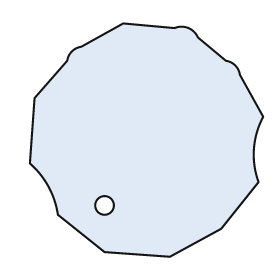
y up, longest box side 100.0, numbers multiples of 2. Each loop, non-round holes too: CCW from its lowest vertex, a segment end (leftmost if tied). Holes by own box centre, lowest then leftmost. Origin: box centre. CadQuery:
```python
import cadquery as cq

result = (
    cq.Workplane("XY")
    .moveTo(10.0, -50.0)
    .lineTo(32.0, -38.0)
    .lineTo(48.0, -18.0)
    .threePointArc((46.0, -4.0), (50.0, 10.0))
    .lineTo(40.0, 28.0)
    .threePointArc((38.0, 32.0), (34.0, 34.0))
    .lineTo(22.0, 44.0)
    .threePointArc((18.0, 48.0), (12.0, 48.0))
    .lineTo(-10.0, 50.0)
    .lineTo(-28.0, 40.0)
    .threePointArc((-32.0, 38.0), (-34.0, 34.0))
    .lineTo(-48.0, 18.0)
    .lineTo(-50.0, -10.0)
    .threePointArc((-42.0, -20.0), (-38.0, -32.0))
    .lineTo(-18.0, -48.0)
    .close()
    .moveTo(-18.0, -28.0)
    .circle(4.0)
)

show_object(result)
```